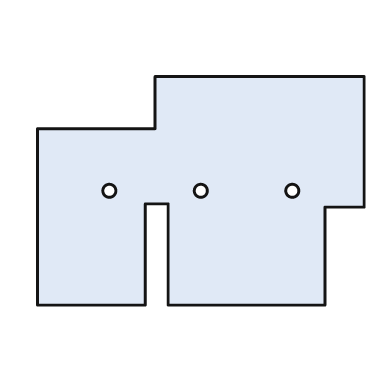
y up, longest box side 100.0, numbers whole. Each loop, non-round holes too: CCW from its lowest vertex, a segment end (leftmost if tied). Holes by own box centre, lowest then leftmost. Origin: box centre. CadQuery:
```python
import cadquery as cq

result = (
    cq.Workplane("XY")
    .moveTo(-50.0, -35.0)
    .lineTo(-17.0, -35.0)
    .lineTo(-17.0, -4.0)
    .lineTo(-10.0, -4.0)
    .lineTo(-10.0, -35.0)
    .lineTo(38.0, -35.0)
    .lineTo(38.0, -5.0)
    .lineTo(50.0, -5.0)
    .lineTo(50.0, 35.0)
    .lineTo(-14.0, 35.0)
    .lineTo(-14.0, 19.0)
    .lineTo(-50.0, 19.0)
    .close()
    .moveTo(-28.0, 0.0)
    .circle(2.0)
    .moveTo(0.0, 0.0)
    .circle(2.0)
    .moveTo(28.0, 0.0)
    .circle(2.0)
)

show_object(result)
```